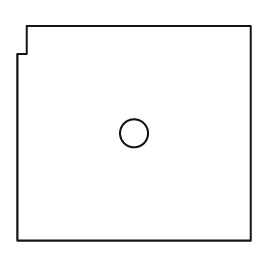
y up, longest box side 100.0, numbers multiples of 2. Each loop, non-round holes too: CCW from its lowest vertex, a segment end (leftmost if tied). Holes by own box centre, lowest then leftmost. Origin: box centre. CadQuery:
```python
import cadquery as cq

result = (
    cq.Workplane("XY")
    .moveTo(-50.0, -46.0)
    .lineTo(50.0, -46.0)
    .lineTo(50.0, 46.0)
    .lineTo(-46.0, 46.0)
    .lineTo(-46.0, 34.0)
    .lineTo(-50.0, 34.0)
    .close()
    .moveTo(0.0, 0.0)
    .circle(6.0)
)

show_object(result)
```